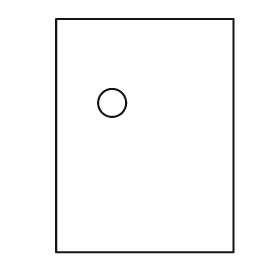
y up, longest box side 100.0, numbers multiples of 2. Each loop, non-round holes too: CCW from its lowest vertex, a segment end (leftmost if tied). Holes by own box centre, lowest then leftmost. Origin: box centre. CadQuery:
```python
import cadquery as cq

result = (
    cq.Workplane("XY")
    .moveTo(-38.0, -50.0)
    .lineTo(38.0, -50.0)
    .lineTo(38.0, 50.0)
    .lineTo(-38.0, 50.0)
    .close()
    .moveTo(-14.0, 14.0)
    .circle(6.0)
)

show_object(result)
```